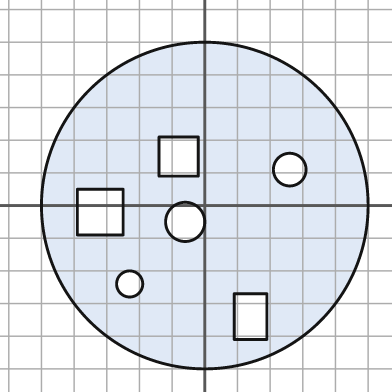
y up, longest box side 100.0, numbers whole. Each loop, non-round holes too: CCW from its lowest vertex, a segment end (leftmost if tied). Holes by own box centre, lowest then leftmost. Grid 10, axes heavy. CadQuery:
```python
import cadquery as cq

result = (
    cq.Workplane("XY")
    .moveTo(0.0, 0.0)
    .circle(50.0)
    .moveTo(9.0, -41.0)
    .lineTo(19.0, -41.0)
    .lineTo(19.0, -27.0)
    .lineTo(9.0, -27.0)
    .close()
    .moveTo(-23.0, -24.0)
    .circle(4.0)
    .moveTo(-6.0, -5.0)
    .circle(6.0)
    .moveTo(-39.0, -9.0)
    .lineTo(-25.0, -9.0)
    .lineTo(-25.0, 5.0)
    .lineTo(-39.0, 5.0)
    .close()
    .moveTo(26.0, 11.0)
    .circle(5.0)
    .moveTo(-14.0, 9.0)
    .lineTo(-2.0, 9.0)
    .lineTo(-2.0, 21.0)
    .lineTo(-14.0, 21.0)
    .close()
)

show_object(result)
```